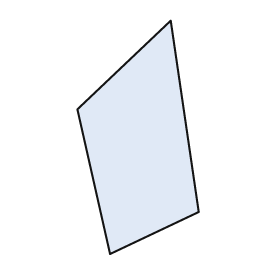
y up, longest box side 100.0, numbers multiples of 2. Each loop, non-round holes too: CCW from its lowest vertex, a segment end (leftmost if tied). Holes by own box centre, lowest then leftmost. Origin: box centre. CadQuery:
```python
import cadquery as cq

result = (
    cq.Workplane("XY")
    .moveTo(-12.0, -50.0)
    .lineTo(26.0, -32.0)
    .lineTo(14.0, 50.0)
    .lineTo(-26.0, 12.0)
    .close()
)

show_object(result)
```